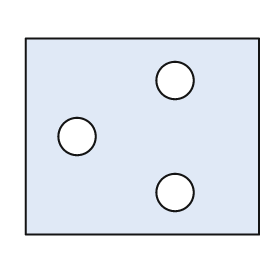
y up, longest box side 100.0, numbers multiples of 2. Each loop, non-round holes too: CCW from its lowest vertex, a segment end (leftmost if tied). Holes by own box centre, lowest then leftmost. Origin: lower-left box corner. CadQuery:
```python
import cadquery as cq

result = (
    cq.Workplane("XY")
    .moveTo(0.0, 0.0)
    .lineTo(100.0, 0.0)
    .lineTo(100.0, 84.0)
    .lineTo(0.0, 84.0)
    .close()
    .moveTo(64.0, 18.0)
    .circle(8.0)
    .moveTo(22.0, 42.0)
    .circle(8.0)
    .moveTo(64.0, 66.0)
    .circle(8.0)
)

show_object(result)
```